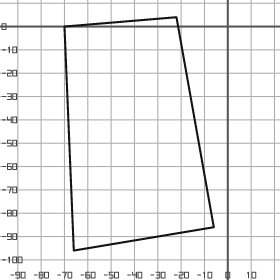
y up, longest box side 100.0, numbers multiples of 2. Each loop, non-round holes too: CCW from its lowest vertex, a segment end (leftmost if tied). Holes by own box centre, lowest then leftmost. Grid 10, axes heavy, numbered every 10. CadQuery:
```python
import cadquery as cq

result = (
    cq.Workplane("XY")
    .moveTo(-66.0, -96.0)
    .lineTo(-6.0, -86.0)
    .lineTo(-22.0, 4.0)
    .lineTo(-70.0, 0.0)
    .close()
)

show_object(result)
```